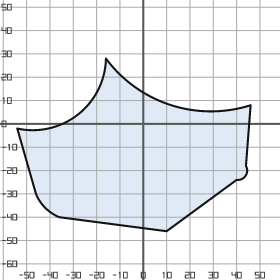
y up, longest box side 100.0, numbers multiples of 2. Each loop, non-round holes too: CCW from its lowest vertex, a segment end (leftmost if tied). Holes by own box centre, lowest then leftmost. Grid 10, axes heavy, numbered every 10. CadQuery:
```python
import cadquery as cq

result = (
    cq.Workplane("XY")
    .moveTo(10.0, -46.0)
    .lineTo(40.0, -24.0)
    .threePointArc((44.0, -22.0), (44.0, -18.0))
    .lineTo(46.0, 8.0)
    .threePointArc((12.0, 8.0), (-16.0, 28.0))
    .threePointArc((-28.0, 4.0), (-54.0, -2.0))
    .lineTo(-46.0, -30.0)
    .threePointArc((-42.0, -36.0), (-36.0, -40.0))
    .close()
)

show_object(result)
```